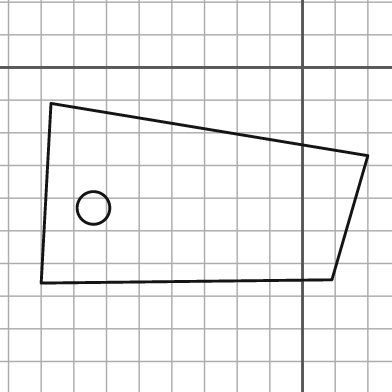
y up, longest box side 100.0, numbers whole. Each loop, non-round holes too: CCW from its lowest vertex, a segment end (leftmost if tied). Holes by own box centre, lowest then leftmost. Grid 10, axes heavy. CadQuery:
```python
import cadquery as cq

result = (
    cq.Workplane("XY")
    .moveTo(-80.0, -66.0)
    .lineTo(9.0, -65.0)
    .lineTo(20.0, -27.0)
    .lineTo(-77.0, -11.0)
    .close()
    .moveTo(-64.0, -43.0)
    .circle(5.0)
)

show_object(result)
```